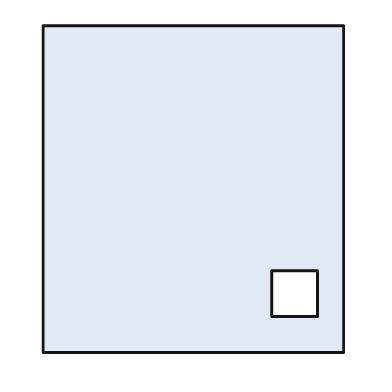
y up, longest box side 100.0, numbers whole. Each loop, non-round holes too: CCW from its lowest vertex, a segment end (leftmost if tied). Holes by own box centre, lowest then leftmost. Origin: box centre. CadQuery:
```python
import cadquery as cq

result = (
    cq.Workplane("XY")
    .moveTo(-46.0, -50.0)
    .lineTo(46.0, -50.0)
    .lineTo(46.0, 50.0)
    .lineTo(-46.0, 50.0)
    .close()
    .moveTo(24.0, -39.0)
    .lineTo(38.0, -39.0)
    .lineTo(38.0, -25.0)
    .lineTo(24.0, -25.0)
    .close()
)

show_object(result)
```